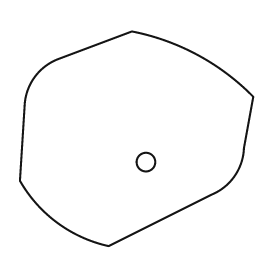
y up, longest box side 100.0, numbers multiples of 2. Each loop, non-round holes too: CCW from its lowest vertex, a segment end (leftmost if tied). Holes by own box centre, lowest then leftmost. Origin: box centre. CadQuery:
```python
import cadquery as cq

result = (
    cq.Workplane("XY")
    .moveTo(-12.0, -46.0)
    .lineTo(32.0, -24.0)
    .threePointArc((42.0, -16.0), (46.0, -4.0))
    .lineTo(50.0, 18.0)
    .threePointArc((26.0, 36.0), (-2.0, 46.0))
    .lineTo(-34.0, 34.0)
    .threePointArc((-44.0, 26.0), (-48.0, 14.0))
    .lineTo(-50.0, -18.0)
    .threePointArc((-34.0, -36.0), (-12.0, -46.0))
    .close()
    .moveTo(4.0, -10.0)
    .circle(4.0)
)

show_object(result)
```